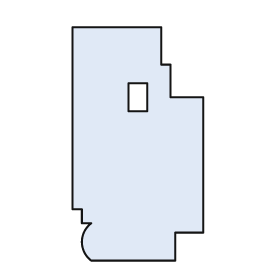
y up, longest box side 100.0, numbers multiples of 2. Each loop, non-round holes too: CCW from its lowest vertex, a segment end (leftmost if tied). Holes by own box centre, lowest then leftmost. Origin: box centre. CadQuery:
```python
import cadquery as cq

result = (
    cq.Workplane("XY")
    .moveTo(-20.0, -50.0)
    .lineTo(16.0, -50.0)
    .lineTo(16.0, -38.0)
    .lineTo(28.0, -38.0)
    .lineTo(28.0, 20.0)
    .lineTo(14.0, 20.0)
    .lineTo(14.0, 34.0)
    .lineTo(10.0, 34.0)
    .lineTo(10.0, 50.0)
    .lineTo(-28.0, 50.0)
    .lineTo(-28.0, -28.0)
    .lineTo(-24.0, -28.0)
    .lineTo(-24.0, -34.0)
    .lineTo(-20.0, -34.0)
    .threePointArc((-24.0, -42.0), (-20.0, -50.0))
    .close()
    .moveTo(-4.0, 14.0)
    .lineTo(4.0, 14.0)
    .lineTo(4.0, 26.0)
    .lineTo(-4.0, 26.0)
    .close()
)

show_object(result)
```